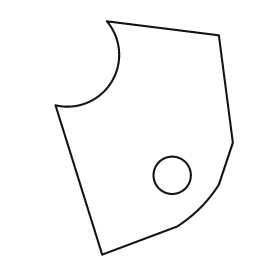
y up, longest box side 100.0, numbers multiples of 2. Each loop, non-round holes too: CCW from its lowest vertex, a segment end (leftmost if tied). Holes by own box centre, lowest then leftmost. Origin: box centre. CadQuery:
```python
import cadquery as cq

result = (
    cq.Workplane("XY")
    .moveTo(-18.0, -50.0)
    .lineTo(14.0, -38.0)
    .threePointArc((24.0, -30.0), (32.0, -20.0))
    .lineTo(38.0, -2.0)
    .lineTo(32.0, 44.0)
    .lineTo(-16.0, 50.0)
    .threePointArc((-14.0, 24.0), (-38.0, 14.0))
    .close()
    .moveTo(12.0, -16.0)
    .circle(8.0)
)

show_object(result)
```